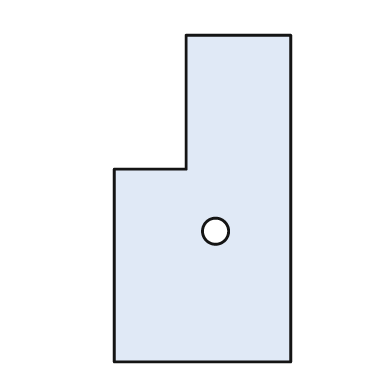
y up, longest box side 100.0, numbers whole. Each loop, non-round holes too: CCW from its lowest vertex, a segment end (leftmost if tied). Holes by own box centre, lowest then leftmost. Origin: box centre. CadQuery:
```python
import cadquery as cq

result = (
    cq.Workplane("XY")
    .moveTo(-27.0, -50.0)
    .lineTo(27.0, -50.0)
    .lineTo(27.0, 50.0)
    .lineTo(-5.0, 50.0)
    .lineTo(-5.0, 9.0)
    .lineTo(-27.0, 9.0)
    .close()
    .moveTo(4.0, -10.0)
    .circle(4.0)
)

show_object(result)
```